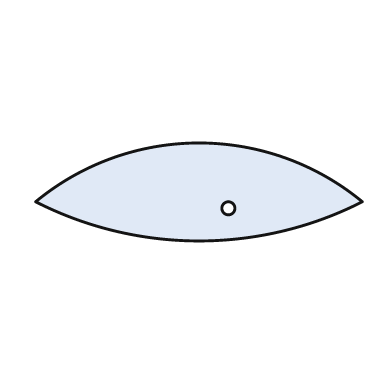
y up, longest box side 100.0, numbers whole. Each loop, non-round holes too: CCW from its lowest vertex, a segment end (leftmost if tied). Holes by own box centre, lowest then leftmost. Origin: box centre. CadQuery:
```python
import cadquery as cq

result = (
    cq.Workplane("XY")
    .moveTo(-50.0, -3.0)
    .threePointArc((0.0, -15.0), (50.0, -3.0))
    .threePointArc((0.0, 15.0), (-50.0, -3.0))
    .close()
    .moveTo(9.0, -5.0)
    .circle(2.0)
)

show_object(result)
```